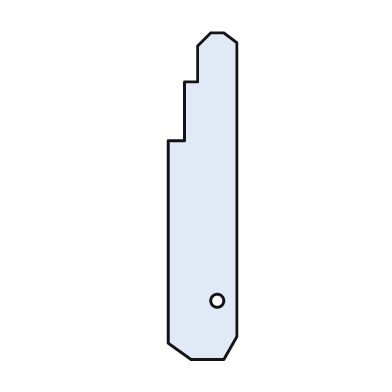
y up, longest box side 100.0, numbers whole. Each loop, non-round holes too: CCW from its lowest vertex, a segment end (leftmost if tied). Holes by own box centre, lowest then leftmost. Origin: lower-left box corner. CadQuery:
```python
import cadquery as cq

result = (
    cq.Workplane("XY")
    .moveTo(7.0, 0.0)
    .lineTo(17.0, 0.0)
    .lineTo(21.0, 7.0)
    .lineTo(21.0, 97.0)
    .lineTo(17.0, 100.0)
    .lineTo(13.0, 100.0)
    .lineTo(9.0, 96.0)
    .lineTo(9.0, 85.0)
    .lineTo(5.0, 85.0)
    .lineTo(5.0, 67.0)
    .lineTo(0.0, 67.0)
    .lineTo(0.0, 5.0)
    .close()
    .moveTo(15.0, 18.0)
    .circle(2.0)
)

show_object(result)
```